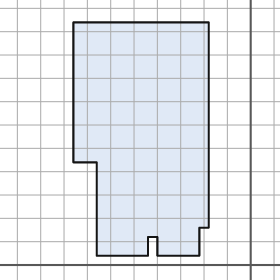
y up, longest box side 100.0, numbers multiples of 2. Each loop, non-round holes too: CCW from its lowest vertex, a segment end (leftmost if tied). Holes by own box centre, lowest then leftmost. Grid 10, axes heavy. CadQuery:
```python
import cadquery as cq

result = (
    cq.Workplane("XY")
    .moveTo(-66.0, 4.0)
    .lineTo(-44.0, 4.0)
    .lineTo(-44.0, 12.0)
    .lineTo(-40.0, 12.0)
    .lineTo(-40.0, 4.0)
    .lineTo(-22.0, 4.0)
    .lineTo(-22.0, 16.0)
    .lineTo(-18.0, 16.0)
    .lineTo(-18.0, 104.0)
    .lineTo(-76.0, 104.0)
    .lineTo(-76.0, 44.0)
    .lineTo(-66.0, 44.0)
    .close()
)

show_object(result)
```